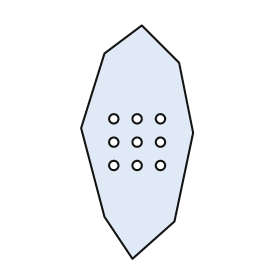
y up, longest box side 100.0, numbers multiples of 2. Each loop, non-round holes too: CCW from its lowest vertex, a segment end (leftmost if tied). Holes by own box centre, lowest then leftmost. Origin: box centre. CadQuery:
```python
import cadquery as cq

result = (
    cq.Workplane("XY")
    .moveTo(-2.0, -50.0)
    .lineTo(16.0, -34.0)
    .lineTo(24.0, 4.0)
    .lineTo(18.0, 34.0)
    .lineTo(2.0, 50.0)
    .lineTo(-14.0, 38.0)
    .lineTo(-24.0, 6.0)
    .lineTo(-14.0, -32.0)
    .close()
    .moveTo(-10.0, -10.0)
    .circle(2.0)
    .moveTo(0.0, -10.0)
    .circle(2.0)
    .moveTo(10.0, -10.0)
    .circle(2.0)
    .moveTo(-10.0, 0.0)
    .circle(2.0)
    .moveTo(0.0, 0.0)
    .circle(2.0)
    .moveTo(10.0, 0.0)
    .circle(2.0)
    .moveTo(-10.0, 10.0)
    .circle(2.0)
    .moveTo(0.0, 10.0)
    .circle(2.0)
    .moveTo(10.0, 10.0)
    .circle(2.0)
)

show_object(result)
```